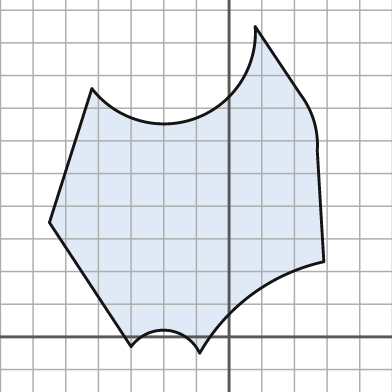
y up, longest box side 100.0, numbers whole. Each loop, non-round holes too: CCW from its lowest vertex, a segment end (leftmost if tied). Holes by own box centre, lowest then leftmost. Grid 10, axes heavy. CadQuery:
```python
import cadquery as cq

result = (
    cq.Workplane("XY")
    .moveTo(-9.0, -5.0)
    .threePointArc((7.0, 13.0), (29.0, 23.0))
    .lineTo(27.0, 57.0)
    .threePointArc((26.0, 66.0), (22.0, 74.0))
    .lineTo(8.0, 95.0)
    .threePointArc((-10.0, 67.0), (-42.0, 76.0))
    .lineTo(-55.0, 35.0)
    .lineTo(-30.0, -3.0)
    .threePointArc((-19.0, 2.0), (-9.0, -5.0))
    .close()
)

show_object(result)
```